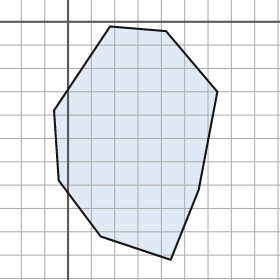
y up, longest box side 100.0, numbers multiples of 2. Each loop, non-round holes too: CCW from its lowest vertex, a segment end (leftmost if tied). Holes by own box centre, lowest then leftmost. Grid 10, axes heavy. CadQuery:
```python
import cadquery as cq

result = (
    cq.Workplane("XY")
    .moveTo(44.0, -102.0)
    .lineTo(56.0, -72.0)
    .lineTo(64.0, -30.0)
    .lineTo(42.0, -4.0)
    .lineTo(18.0, -2.0)
    .lineTo(-6.0, -38.0)
    .lineTo(-4.0, -68.0)
    .lineTo(14.0, -92.0)
    .close()
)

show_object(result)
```